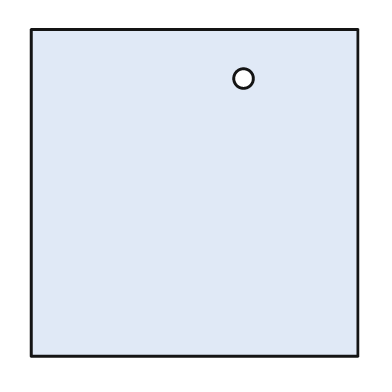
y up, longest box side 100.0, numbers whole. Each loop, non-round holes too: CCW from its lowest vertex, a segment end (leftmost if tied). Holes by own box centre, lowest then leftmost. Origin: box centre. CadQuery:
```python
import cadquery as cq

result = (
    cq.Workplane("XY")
    .moveTo(-50.0, -50.0)
    .lineTo(50.0, -50.0)
    .lineTo(50.0, 50.0)
    .lineTo(-50.0, 50.0)
    .close()
    .moveTo(15.0, 35.0)
    .circle(3.0)
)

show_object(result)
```